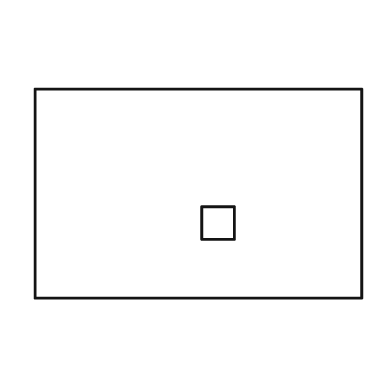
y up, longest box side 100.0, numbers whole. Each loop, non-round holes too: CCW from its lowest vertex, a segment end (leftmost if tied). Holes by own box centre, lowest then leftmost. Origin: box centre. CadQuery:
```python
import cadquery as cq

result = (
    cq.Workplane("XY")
    .moveTo(-50.0, -32.0)
    .lineTo(50.0, -32.0)
    .lineTo(50.0, 32.0)
    .lineTo(-50.0, 32.0)
    .close()
    .moveTo(1.0, -14.0)
    .lineTo(11.0, -14.0)
    .lineTo(11.0, -4.0)
    .lineTo(1.0, -4.0)
    .close()
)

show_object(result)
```